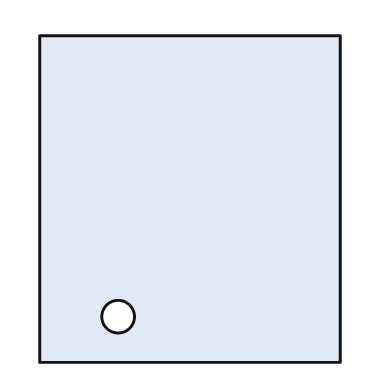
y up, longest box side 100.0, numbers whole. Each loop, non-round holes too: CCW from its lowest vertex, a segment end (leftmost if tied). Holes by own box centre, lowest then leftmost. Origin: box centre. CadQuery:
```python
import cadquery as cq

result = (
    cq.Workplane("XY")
    .moveTo(-46.0, -50.0)
    .lineTo(46.0, -50.0)
    .lineTo(46.0, 50.0)
    .lineTo(-46.0, 50.0)
    .close()
    .moveTo(-22.0, -36.0)
    .circle(5.0)
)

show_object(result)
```